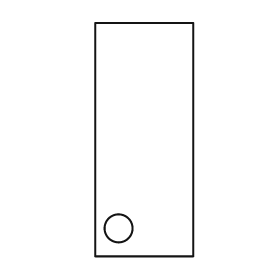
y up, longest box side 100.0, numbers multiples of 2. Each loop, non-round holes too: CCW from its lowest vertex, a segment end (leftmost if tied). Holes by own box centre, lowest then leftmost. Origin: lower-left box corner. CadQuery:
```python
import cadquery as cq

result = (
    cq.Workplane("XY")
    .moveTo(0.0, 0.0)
    .lineTo(42.0, 0.0)
    .lineTo(42.0, 100.0)
    .lineTo(0.0, 100.0)
    .close()
    .moveTo(10.0, 12.0)
    .circle(6.0)
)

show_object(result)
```